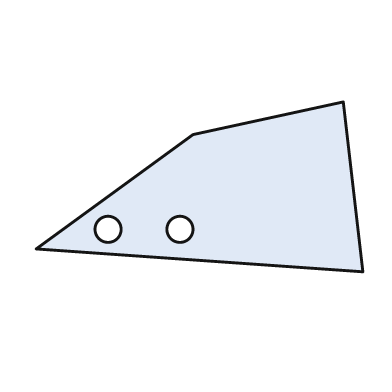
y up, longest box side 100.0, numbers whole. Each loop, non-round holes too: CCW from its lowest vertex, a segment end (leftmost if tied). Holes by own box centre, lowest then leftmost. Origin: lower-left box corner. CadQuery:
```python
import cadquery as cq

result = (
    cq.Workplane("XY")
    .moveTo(100.0, 0.0)
    .lineTo(94.0, 52.0)
    .lineTo(48.0, 42.0)
    .lineTo(0.0, 7.0)
    .close()
    .moveTo(22.0, 13.0)
    .circle(4.0)
    .moveTo(44.0, 13.0)
    .circle(4.0)
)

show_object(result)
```